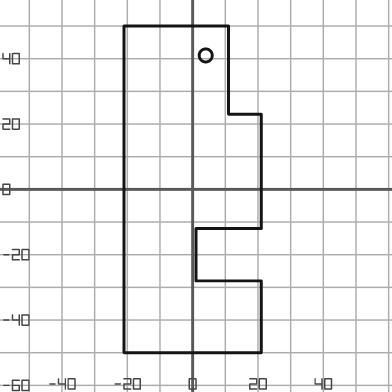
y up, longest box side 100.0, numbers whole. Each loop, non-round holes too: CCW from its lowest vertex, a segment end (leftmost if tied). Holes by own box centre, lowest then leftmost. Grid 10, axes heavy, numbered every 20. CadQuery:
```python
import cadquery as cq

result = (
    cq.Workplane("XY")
    .moveTo(-21.0, -50.0)
    .lineTo(21.0, -50.0)
    .lineTo(21.0, -28.0)
    .lineTo(1.0, -28.0)
    .lineTo(1.0, -12.0)
    .lineTo(21.0, -12.0)
    .lineTo(21.0, 23.0)
    .lineTo(11.0, 23.0)
    .lineTo(11.0, 50.0)
    .lineTo(-21.0, 50.0)
    .close()
    .moveTo(4.0, 41.0)
    .circle(2.0)
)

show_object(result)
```